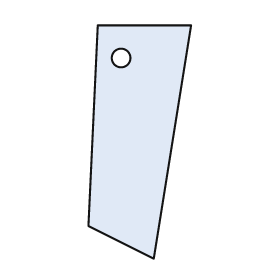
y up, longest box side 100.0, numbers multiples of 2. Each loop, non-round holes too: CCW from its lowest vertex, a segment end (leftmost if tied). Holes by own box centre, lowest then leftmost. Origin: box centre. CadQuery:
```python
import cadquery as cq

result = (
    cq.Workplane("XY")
    .moveTo(6.0, -50.0)
    .lineTo(22.0, 50.0)
    .lineTo(-18.0, 50.0)
    .lineTo(-22.0, -36.0)
    .close()
    .moveTo(-8.0, 36.0)
    .circle(4.0)
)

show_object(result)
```